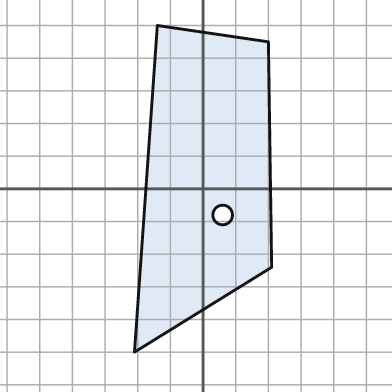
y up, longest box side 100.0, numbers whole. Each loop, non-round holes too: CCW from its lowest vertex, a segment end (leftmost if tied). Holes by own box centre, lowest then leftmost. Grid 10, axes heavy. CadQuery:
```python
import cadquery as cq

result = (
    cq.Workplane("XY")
    .moveTo(-21.0, -50.0)
    .lineTo(21.0, -24.0)
    .lineTo(20.0, 45.0)
    .lineTo(-14.0, 50.0)
    .close()
    .moveTo(6.0, -8.0)
    .circle(3.0)
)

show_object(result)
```